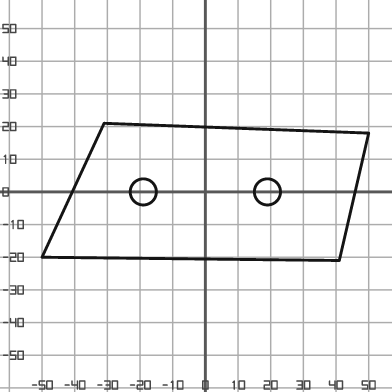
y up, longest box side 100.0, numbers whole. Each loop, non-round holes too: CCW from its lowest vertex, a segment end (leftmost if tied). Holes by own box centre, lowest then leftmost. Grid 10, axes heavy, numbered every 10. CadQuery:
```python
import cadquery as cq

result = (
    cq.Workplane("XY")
    .moveTo(41.0, -21.0)
    .lineTo(50.0, 18.0)
    .lineTo(-31.0, 21.0)
    .lineTo(-50.0, -20.0)
    .close()
    .moveTo(-19.0, 0.0)
    .circle(4.0)
    .moveTo(19.0, 0.0)
    .circle(4.0)
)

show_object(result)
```